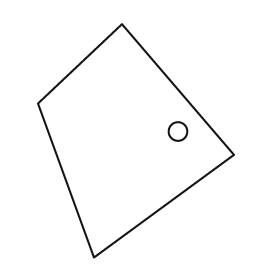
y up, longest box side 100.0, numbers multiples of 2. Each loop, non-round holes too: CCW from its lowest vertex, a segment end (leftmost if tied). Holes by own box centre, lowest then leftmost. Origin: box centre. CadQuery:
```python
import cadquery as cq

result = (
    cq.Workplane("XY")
    .moveTo(-18.0, -50.0)
    .lineTo(42.0, -6.0)
    .lineTo(-6.0, 50.0)
    .lineTo(-42.0, 16.0)
    .close()
    .moveTo(18.0, 4.0)
    .circle(4.0)
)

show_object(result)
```